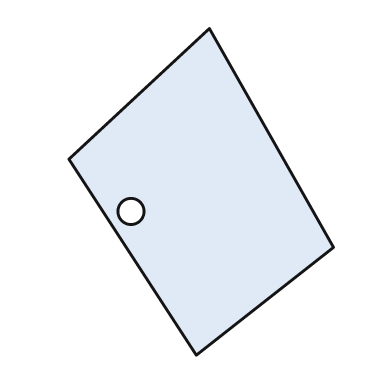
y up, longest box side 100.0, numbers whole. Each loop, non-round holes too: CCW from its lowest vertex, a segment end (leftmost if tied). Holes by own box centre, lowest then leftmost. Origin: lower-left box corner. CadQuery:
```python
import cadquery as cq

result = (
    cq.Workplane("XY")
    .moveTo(39.0, 0.0)
    .lineTo(81.0, 33.0)
    .lineTo(43.0, 100.0)
    .lineTo(0.0, 60.0)
    .close()
    .moveTo(19.0, 44.0)
    .circle(4.0)
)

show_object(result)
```